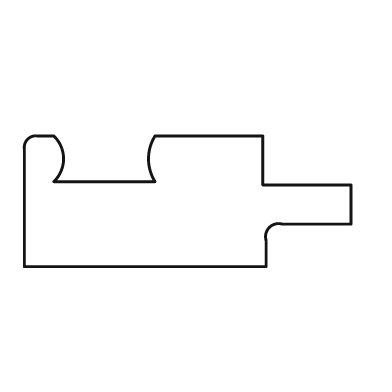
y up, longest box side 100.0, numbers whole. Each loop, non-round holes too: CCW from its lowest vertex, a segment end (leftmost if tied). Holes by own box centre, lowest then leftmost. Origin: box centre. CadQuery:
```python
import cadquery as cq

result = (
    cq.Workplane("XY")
    .moveTo(-50.0, -20.0)
    .lineTo(24.0, -20.0)
    .lineTo(24.0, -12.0)
    .threePointArc((25.0, -8.0), (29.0, -7.0))
    .lineTo(50.0, -7.0)
    .lineTo(50.0, 5.0)
    .lineTo(23.0, 5.0)
    .lineTo(23.0, 20.0)
    .lineTo(-10.0, 20.0)
    .threePointArc((-12.0, 13.0), (-10.0, 6.0))
    .lineTo(-41.0, 6.0)
    .threePointArc((-38.0, 13.0), (-41.0, 20.0))
    .lineTo(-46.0, 20.0)
    .threePointArc((-49.0, 19.0), (-50.0, 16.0))
    .close()
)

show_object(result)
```